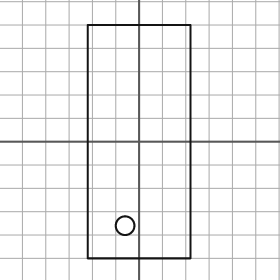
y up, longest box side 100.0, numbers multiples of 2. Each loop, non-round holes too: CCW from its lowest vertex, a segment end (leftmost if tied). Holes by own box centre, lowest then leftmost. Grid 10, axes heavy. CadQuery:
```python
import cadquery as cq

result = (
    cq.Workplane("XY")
    .moveTo(-22.0, -50.0)
    .lineTo(22.0, -50.0)
    .lineTo(22.0, 50.0)
    .lineTo(-22.0, 50.0)
    .close()
    .moveTo(-6.0, -36.0)
    .circle(4.0)
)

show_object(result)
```